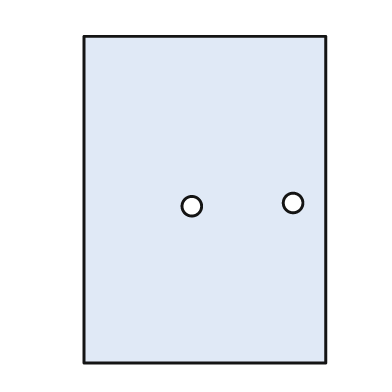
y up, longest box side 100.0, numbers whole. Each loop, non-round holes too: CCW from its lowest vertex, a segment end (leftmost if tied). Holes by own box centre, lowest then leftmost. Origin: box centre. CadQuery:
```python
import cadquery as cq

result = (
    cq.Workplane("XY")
    .moveTo(-37.0, -50.0)
    .lineTo(37.0, -50.0)
    .lineTo(37.0, 50.0)
    .lineTo(-37.0, 50.0)
    .close()
    .moveTo(-4.0, -2.0)
    .circle(3.0)
    .moveTo(27.0, -1.0)
    .circle(3.0)
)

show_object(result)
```